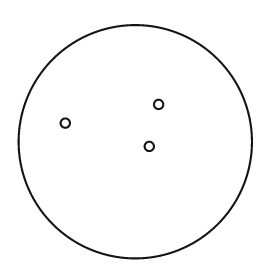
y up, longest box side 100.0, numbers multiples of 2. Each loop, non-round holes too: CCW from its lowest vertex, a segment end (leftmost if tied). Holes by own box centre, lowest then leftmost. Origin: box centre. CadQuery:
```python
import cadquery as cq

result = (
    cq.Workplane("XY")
    .moveTo(0.0, 0.0)
    .circle(50.0)
    .moveTo(6.0, -2.0)
    .circle(2.0)
    .moveTo(-30.0, 8.0)
    .circle(2.0)
    .moveTo(10.0, 16.0)
    .circle(2.0)
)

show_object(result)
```